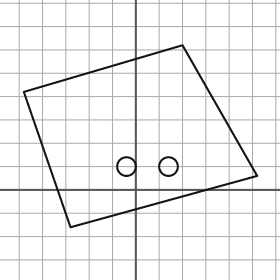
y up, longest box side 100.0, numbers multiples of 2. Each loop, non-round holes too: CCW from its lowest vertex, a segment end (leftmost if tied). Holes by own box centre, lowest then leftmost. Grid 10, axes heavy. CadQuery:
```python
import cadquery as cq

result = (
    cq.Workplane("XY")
    .moveTo(-28.0, -16.0)
    .lineTo(52.0, 6.0)
    .lineTo(20.0, 62.0)
    .lineTo(-48.0, 42.0)
    .close()
    .moveTo(-4.0, 10.0)
    .circle(4.0)
    .moveTo(14.0, 10.0)
    .circle(4.0)
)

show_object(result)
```